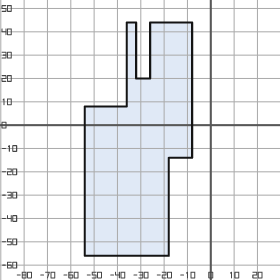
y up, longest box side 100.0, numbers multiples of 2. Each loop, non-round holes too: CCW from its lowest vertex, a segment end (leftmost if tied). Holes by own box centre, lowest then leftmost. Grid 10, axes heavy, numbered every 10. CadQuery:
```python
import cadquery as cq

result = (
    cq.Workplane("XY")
    .moveTo(-54.0, -56.0)
    .lineTo(-18.0, -56.0)
    .lineTo(-18.0, -14.0)
    .lineTo(-8.0, -14.0)
    .lineTo(-8.0, 44.0)
    .lineTo(-26.0, 44.0)
    .lineTo(-26.0, 20.0)
    .lineTo(-32.0, 20.0)
    .lineTo(-32.0, 44.0)
    .lineTo(-36.0, 44.0)
    .lineTo(-36.0, 8.0)
    .lineTo(-54.0, 8.0)
    .close()
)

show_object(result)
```